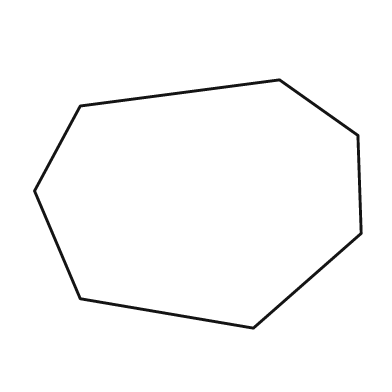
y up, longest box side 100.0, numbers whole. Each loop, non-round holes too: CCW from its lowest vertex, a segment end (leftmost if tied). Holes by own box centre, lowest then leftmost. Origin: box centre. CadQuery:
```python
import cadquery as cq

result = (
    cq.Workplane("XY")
    .moveTo(17.0, -38.0)
    .lineTo(50.0, -9.0)
    .lineTo(49.0, 21.0)
    .lineTo(25.0, 38.0)
    .lineTo(-36.0, 30.0)
    .lineTo(-50.0, 4.0)
    .lineTo(-36.0, -29.0)
    .close()
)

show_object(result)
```